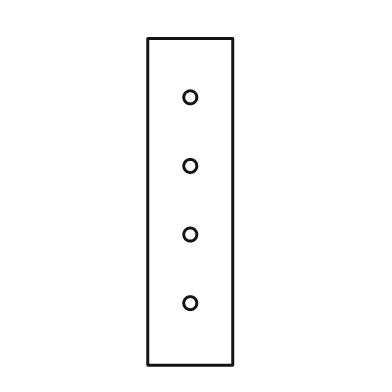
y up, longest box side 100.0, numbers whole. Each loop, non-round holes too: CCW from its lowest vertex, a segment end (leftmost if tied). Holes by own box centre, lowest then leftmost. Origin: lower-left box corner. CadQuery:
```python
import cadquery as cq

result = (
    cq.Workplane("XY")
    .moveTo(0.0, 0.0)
    .lineTo(26.0, 0.0)
    .lineTo(26.0, 100.0)
    .lineTo(0.0, 100.0)
    .close()
    .moveTo(13.0, 19.0)
    .circle(2.0)
    .moveTo(13.0, 40.0)
    .circle(2.0)
    .moveTo(13.0, 61.0)
    .circle(2.0)
    .moveTo(13.0, 82.0)
    .circle(2.0)
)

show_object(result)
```